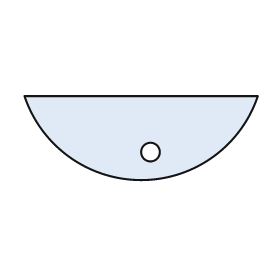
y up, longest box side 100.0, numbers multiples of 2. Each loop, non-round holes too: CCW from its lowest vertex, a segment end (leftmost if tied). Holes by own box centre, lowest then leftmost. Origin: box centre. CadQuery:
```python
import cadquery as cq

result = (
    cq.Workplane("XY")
    .moveTo(-50.0, 18.0)
    .threePointArc((0.0, -18.0), (50.0, 18.0))
    .close()
    .moveTo(4.0, -6.0)
    .circle(4.0)
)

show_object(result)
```